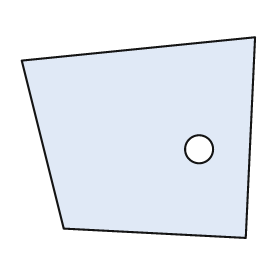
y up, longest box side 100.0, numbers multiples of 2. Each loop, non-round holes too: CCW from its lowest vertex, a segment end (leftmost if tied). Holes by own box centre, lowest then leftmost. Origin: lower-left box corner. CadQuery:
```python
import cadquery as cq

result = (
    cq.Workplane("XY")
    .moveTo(96.0, 0.0)
    .lineTo(100.0, 86.0)
    .lineTo(0.0, 76.0)
    .lineTo(18.0, 4.0)
    .close()
    .moveTo(76.0, 38.0)
    .circle(6.0)
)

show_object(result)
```